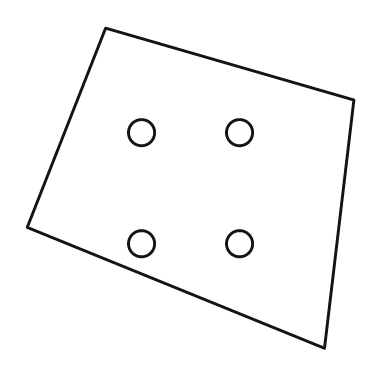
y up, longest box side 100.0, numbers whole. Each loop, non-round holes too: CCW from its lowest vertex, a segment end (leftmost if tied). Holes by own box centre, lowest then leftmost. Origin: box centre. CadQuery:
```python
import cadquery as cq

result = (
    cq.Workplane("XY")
    .moveTo(41.0, -49.0)
    .lineTo(50.0, 27.0)
    .lineTo(-26.0, 49.0)
    .lineTo(-50.0, -12.0)
    .close()
    .moveTo(-15.0, -17.0)
    .circle(4.0)
    .moveTo(15.0, -17.0)
    .circle(4.0)
    .moveTo(-15.0, 17.0)
    .circle(4.0)
    .moveTo(15.0, 17.0)
    .circle(4.0)
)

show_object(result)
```